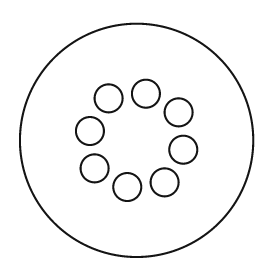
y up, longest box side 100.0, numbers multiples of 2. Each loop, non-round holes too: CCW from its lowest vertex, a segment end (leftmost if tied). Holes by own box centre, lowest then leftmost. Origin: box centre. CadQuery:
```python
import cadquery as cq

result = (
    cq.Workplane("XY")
    .moveTo(0.0, 0.0)
    .circle(50.0)
    .moveTo(-4.0, -20.0)
    .circle(6.0)
    .moveTo(12.0, -18.0)
    .circle(6.0)
    .moveTo(-18.0, -12.0)
    .circle(6.0)
    .moveTo(20.0, -4.0)
    .circle(6.0)
    .moveTo(-20.0, 4.0)
    .circle(6.0)
    .moveTo(18.0, 12.0)
    .circle(6.0)
    .moveTo(-12.0, 18.0)
    .circle(6.0)
    .moveTo(4.0, 20.0)
    .circle(6.0)
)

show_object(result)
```